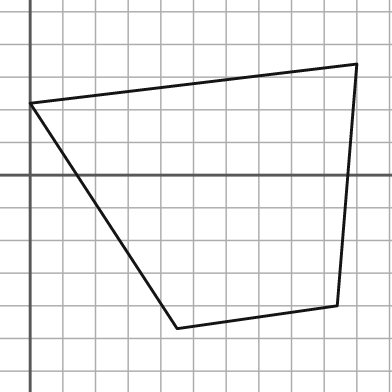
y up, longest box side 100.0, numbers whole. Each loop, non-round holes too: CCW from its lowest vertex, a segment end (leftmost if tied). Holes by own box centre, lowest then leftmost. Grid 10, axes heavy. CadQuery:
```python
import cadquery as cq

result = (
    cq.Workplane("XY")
    .moveTo(45.0, -47.0)
    .lineTo(94.0, -40.0)
    .lineTo(100.0, 34.0)
    .lineTo(0.0, 22.0)
    .close()
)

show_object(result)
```